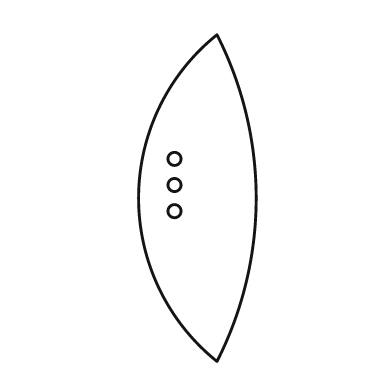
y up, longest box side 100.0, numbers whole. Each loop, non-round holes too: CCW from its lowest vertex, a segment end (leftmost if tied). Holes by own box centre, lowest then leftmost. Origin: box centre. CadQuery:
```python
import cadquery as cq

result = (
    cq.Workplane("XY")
    .moveTo(6.0, -50.0)
    .threePointArc((18.0, 0.0), (6.0, 50.0))
    .threePointArc((-18.0, 0.0), (6.0, -50.0))
    .close()
    .moveTo(-7.0, -4.0)
    .circle(2.0)
    .moveTo(-7.0, 4.0)
    .circle(2.0)
    .moveTo(-7.0, 12.0)
    .circle(2.0)
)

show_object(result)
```